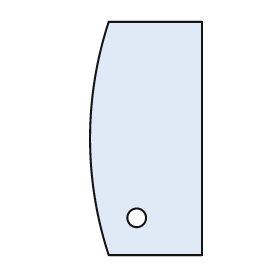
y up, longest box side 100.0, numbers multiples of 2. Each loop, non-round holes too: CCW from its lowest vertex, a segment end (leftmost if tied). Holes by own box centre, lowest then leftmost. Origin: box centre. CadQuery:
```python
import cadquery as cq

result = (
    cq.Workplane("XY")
    .moveTo(-16.0, -50.0)
    .lineTo(24.0, -50.0)
    .lineTo(24.0, 50.0)
    .lineTo(-16.0, 50.0)
    .threePointArc((-24.0, 0.0), (-16.0, -50.0))
    .close()
    .moveTo(-4.0, -34.0)
    .circle(4.0)
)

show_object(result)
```